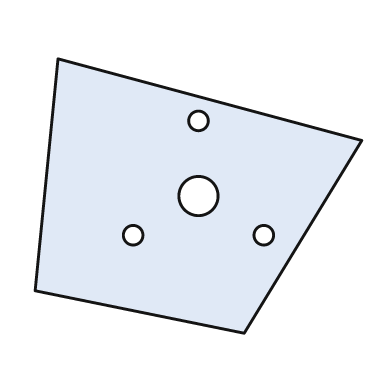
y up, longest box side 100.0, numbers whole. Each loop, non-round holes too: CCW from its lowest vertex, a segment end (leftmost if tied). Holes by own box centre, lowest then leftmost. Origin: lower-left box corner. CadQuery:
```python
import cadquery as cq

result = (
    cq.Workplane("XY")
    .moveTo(64.0, 0.0)
    .lineTo(100.0, 59.0)
    .lineTo(7.0, 84.0)
    .lineTo(0.0, 13.0)
    .close()
    .moveTo(30.0, 30.0)
    .circle(3.0)
    .moveTo(70.0, 30.0)
    .circle(3.0)
    .moveTo(50.0, 42.0)
    .circle(6.0)
    .moveTo(50.0, 65.0)
    .circle(3.0)
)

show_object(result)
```